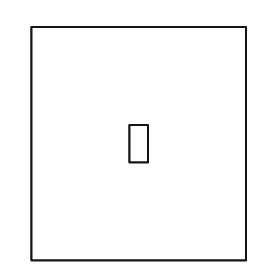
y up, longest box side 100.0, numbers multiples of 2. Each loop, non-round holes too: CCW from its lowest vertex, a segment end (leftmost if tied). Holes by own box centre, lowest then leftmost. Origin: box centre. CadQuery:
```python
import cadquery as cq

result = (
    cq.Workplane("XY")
    .moveTo(-46.0, -50.0)
    .lineTo(46.0, -50.0)
    .lineTo(46.0, 50.0)
    .lineTo(-46.0, 50.0)
    .close()
    .moveTo(-4.0, -8.0)
    .lineTo(4.0, -8.0)
    .lineTo(4.0, 8.0)
    .lineTo(-4.0, 8.0)
    .close()
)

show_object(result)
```